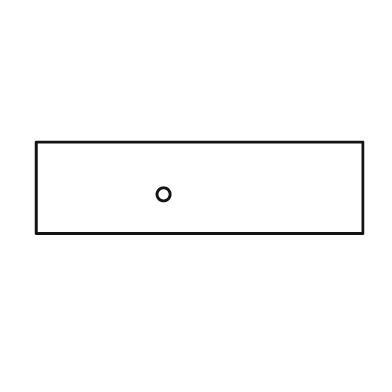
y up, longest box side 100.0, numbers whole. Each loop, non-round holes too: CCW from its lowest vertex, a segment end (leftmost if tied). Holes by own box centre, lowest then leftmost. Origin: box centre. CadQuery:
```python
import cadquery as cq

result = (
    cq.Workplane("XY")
    .moveTo(-50.0, -14.0)
    .lineTo(50.0, -14.0)
    .lineTo(50.0, 14.0)
    .lineTo(-50.0, 14.0)
    .close()
    .moveTo(-11.0, -2.0)
    .circle(2.0)
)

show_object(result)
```